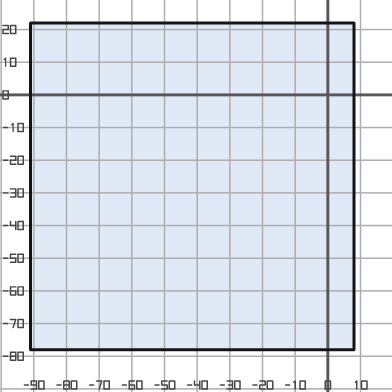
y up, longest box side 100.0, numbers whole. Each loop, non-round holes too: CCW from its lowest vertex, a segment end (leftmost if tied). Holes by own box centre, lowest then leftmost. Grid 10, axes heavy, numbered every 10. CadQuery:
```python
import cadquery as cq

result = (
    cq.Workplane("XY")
    .moveTo(-91.0, -78.0)
    .lineTo(8.0, -78.0)
    .lineTo(8.0, 22.0)
    .lineTo(-91.0, 22.0)
    .close()
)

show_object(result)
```